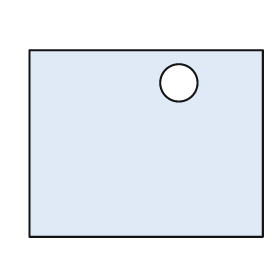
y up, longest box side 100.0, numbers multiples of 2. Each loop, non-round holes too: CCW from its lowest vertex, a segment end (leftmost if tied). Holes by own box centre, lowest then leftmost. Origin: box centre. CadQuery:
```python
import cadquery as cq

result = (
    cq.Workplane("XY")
    .moveTo(-50.0, -40.0)
    .lineTo(50.0, -40.0)
    .lineTo(50.0, 40.0)
    .lineTo(-50.0, 40.0)
    .close()
    .moveTo(14.0, 26.0)
    .circle(8.0)
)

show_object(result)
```